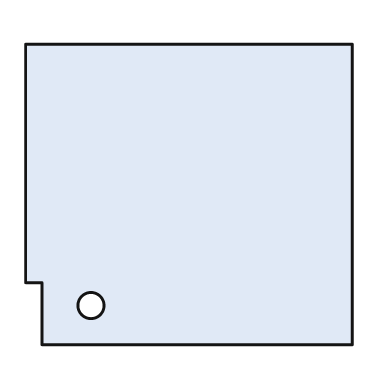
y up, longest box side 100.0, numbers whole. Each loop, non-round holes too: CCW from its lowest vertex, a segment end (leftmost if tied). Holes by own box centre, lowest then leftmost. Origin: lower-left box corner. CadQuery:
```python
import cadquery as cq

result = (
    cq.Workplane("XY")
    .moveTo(5.0, 0.0)
    .lineTo(100.0, 0.0)
    .lineTo(100.0, 92.0)
    .lineTo(0.0, 92.0)
    .lineTo(0.0, 19.0)
    .lineTo(5.0, 19.0)
    .close()
    .moveTo(20.0, 12.0)
    .circle(4.0)
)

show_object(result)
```